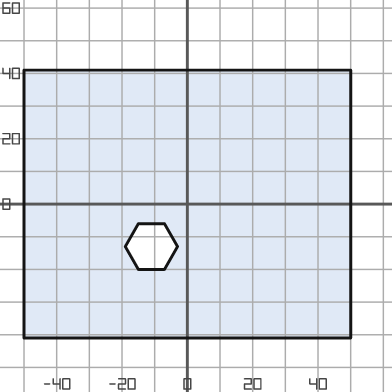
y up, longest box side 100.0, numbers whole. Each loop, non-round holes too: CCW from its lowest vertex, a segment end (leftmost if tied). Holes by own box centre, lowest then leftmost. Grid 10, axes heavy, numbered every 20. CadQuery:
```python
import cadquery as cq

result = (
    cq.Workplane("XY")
    .moveTo(-50.0, -41.0)
    .lineTo(50.0, -41.0)
    .lineTo(50.0, 41.0)
    .lineTo(-50.0, 41.0)
    .close()
    .moveTo(-15.0, -20.0)
    .lineTo(-7.0, -20.0)
    .lineTo(-3.0, -13.0)
    .lineTo(-7.0, -6.0)
    .lineTo(-15.0, -6.0)
    .lineTo(-19.0, -13.0)
    .close()
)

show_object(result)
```